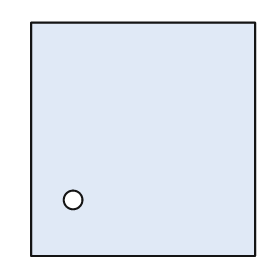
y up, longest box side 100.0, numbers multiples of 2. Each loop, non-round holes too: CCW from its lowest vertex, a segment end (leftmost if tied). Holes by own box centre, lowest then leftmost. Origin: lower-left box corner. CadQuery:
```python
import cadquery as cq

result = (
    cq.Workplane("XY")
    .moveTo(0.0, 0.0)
    .lineTo(96.0, 0.0)
    .lineTo(96.0, 100.0)
    .lineTo(0.0, 100.0)
    .close()
    .moveTo(18.0, 24.0)
    .circle(4.0)
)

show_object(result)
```